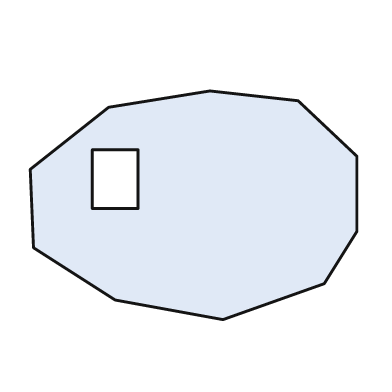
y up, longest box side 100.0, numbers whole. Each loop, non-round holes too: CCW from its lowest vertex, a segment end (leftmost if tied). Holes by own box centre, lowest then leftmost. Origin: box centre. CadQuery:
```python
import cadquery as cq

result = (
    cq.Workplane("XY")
    .moveTo(9.0, -35.0)
    .lineTo(40.0, -24.0)
    .lineTo(50.0, -8.0)
    .lineTo(50.0, 15.0)
    .lineTo(32.0, 32.0)
    .lineTo(5.0, 35.0)
    .lineTo(-26.0, 30.0)
    .lineTo(-50.0, 11.0)
    .lineTo(-49.0, -13.0)
    .lineTo(-24.0, -29.0)
    .close()
    .moveTo(-31.0, -1.0)
    .lineTo(-17.0, -1.0)
    .lineTo(-17.0, 17.0)
    .lineTo(-31.0, 17.0)
    .close()
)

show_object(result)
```